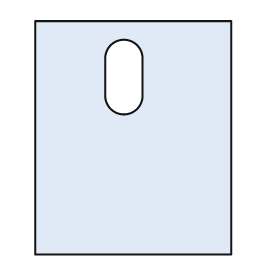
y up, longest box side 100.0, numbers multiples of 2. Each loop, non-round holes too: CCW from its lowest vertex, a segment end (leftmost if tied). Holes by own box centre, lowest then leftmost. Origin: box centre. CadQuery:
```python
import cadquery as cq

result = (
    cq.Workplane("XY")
    .moveTo(-42.0, -50.0)
    .lineTo(42.0, -50.0)
    .lineTo(42.0, 50.0)
    .lineTo(-42.0, 50.0)
    .close()
    .moveTo(-12.0, 18.0)
    .threePointArc((-4.0, 10.0), (4.0, 18.0))
    .lineTo(4.0, 34.0)
    .threePointArc((-4.0, 42.0), (-12.0, 34.0))
    .close()
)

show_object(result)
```